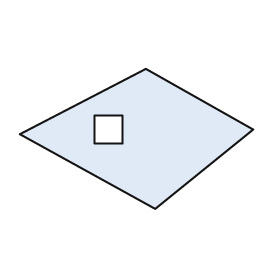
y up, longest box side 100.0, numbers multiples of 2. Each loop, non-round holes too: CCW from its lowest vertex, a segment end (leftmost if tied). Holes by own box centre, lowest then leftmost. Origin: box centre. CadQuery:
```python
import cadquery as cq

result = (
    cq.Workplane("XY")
    .moveTo(8.0, -30.0)
    .lineTo(50.0, 4.0)
    .lineTo(4.0, 30.0)
    .lineTo(-50.0, 2.0)
    .close()
    .moveTo(-18.0, -2.0)
    .lineTo(-6.0, -2.0)
    .lineTo(-6.0, 10.0)
    .lineTo(-18.0, 10.0)
    .close()
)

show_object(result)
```